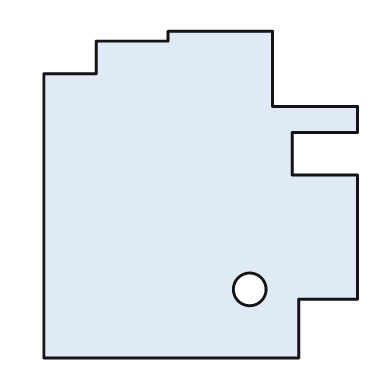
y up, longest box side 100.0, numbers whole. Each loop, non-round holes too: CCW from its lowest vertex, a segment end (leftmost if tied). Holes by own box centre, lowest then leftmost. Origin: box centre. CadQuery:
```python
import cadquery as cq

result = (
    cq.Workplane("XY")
    .moveTo(-48.0, -50.0)
    .lineTo(30.0, -50.0)
    .lineTo(30.0, -32.0)
    .lineTo(48.0, -32.0)
    .lineTo(48.0, 6.0)
    .lineTo(28.0, 6.0)
    .lineTo(28.0, 19.0)
    .lineTo(48.0, 19.0)
    .lineTo(48.0, 27.0)
    .lineTo(22.0, 27.0)
    .lineTo(22.0, 50.0)
    .lineTo(-10.0, 50.0)
    .lineTo(-10.0, 47.0)
    .lineTo(-32.0, 47.0)
    .lineTo(-32.0, 37.0)
    .lineTo(-48.0, 37.0)
    .close()
    .moveTo(15.0, -29.0)
    .circle(5.0)
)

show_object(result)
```